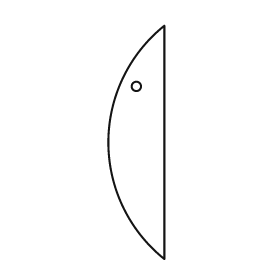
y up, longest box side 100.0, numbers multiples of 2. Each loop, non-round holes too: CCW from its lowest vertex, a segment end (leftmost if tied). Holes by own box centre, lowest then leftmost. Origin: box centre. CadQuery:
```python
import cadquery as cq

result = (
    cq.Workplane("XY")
    .moveTo(12.0, -50.0)
    .lineTo(12.0, 50.0)
    .threePointArc((-12.0, 0.0), (12.0, -50.0))
    .close()
    .moveTo(0.0, 24.0)
    .circle(2.0)
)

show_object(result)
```